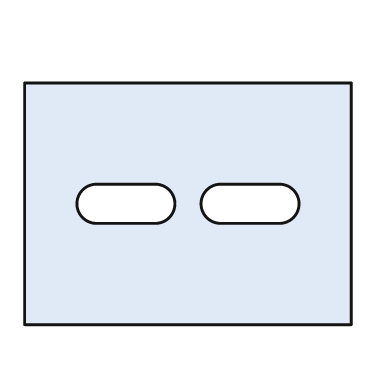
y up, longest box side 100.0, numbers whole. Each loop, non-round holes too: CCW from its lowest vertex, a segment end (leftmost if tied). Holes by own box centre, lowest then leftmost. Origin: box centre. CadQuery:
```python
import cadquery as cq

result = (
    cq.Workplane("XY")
    .moveTo(-50.0, -37.0)
    .lineTo(50.0, -37.0)
    .lineTo(50.0, 37.0)
    .lineTo(-50.0, 37.0)
    .close()
    .moveTo(-28.0, -6.0)
    .lineTo(-10.0, -6.0)
    .threePointArc((-4.0, 0.0), (-10.0, 6.0))
    .lineTo(-28.0, 6.0)
    .threePointArc((-34.0, 0.0), (-28.0, -6.0))
    .close()
    .moveTo(10.0, -6.0)
    .lineTo(28.0, -6.0)
    .threePointArc((34.0, 0.0), (28.0, 6.0))
    .lineTo(10.0, 6.0)
    .threePointArc((4.0, 0.0), (10.0, -6.0))
    .close()
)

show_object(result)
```